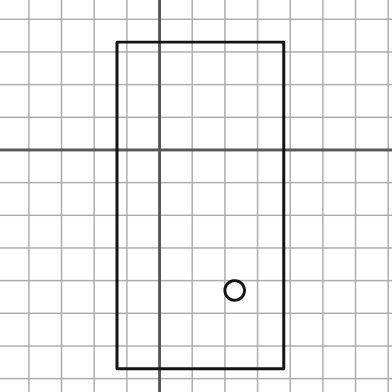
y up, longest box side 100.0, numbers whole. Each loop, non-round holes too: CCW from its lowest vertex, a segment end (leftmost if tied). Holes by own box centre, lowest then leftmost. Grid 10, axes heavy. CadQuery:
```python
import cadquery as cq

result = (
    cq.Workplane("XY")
    .moveTo(-13.0, -67.0)
    .lineTo(38.0, -67.0)
    .lineTo(38.0, 33.0)
    .lineTo(-13.0, 33.0)
    .close()
    .moveTo(23.0, -43.0)
    .circle(3.0)
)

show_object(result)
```